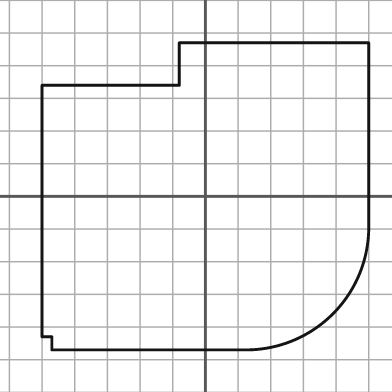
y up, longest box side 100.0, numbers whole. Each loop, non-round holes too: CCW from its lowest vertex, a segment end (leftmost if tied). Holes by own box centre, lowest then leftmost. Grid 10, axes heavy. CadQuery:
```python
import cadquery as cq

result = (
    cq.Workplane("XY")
    .moveTo(-47.0, -47.0)
    .lineTo(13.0, -47.0)
    .threePointArc((39.0, -36.0), (50.0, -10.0))
    .lineTo(50.0, 47.0)
    .lineTo(-8.0, 47.0)
    .lineTo(-8.0, 34.0)
    .lineTo(-50.0, 34.0)
    .lineTo(-50.0, -43.0)
    .lineTo(-47.0, -43.0)
    .close()
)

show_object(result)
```